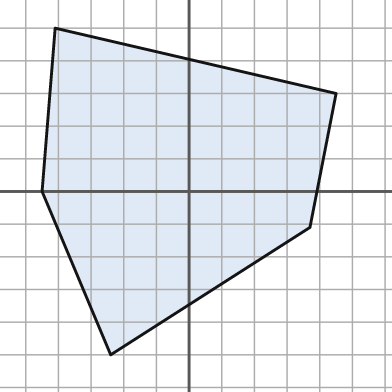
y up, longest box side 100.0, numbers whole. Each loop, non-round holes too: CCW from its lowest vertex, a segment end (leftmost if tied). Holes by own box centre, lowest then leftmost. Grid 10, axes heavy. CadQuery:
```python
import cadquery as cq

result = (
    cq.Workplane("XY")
    .moveTo(-24.0, -50.0)
    .lineTo(37.0, -11.0)
    .lineTo(45.0, 30.0)
    .lineTo(-41.0, 50.0)
    .lineTo(-45.0, 0.0)
    .close()
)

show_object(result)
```